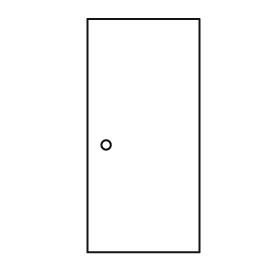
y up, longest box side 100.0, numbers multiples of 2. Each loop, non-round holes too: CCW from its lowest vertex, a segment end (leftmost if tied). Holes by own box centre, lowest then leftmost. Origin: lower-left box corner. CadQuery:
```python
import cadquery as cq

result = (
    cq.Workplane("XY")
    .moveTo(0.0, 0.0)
    .lineTo(48.0, 0.0)
    .lineTo(48.0, 100.0)
    .lineTo(0.0, 100.0)
    .close()
    .moveTo(8.0, 46.0)
    .circle(2.0)
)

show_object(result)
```